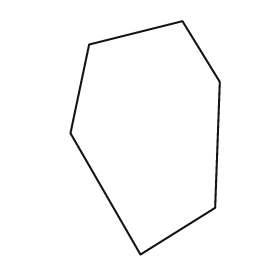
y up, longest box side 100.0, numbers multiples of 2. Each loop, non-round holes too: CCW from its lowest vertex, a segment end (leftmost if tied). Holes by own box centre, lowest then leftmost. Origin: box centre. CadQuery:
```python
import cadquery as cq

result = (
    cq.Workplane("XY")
    .moveTo(-2.0, -50.0)
    .lineTo(30.0, -30.0)
    .lineTo(32.0, 24.0)
    .lineTo(16.0, 50.0)
    .lineTo(-24.0, 40.0)
    .lineTo(-32.0, 2.0)
    .close()
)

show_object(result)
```